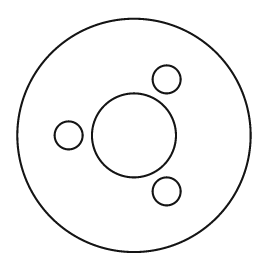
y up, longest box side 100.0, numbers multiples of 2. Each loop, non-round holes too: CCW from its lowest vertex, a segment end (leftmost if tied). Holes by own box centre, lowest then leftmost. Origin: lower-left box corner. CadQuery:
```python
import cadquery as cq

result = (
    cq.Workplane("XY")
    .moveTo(50.0, 50.0)
    .circle(50.0)
    .moveTo(64.0, 26.0)
    .circle(6.0)
    .moveTo(22.0, 50.0)
    .circle(6.0)
    .moveTo(50.0, 50.0)
    .circle(18.0)
    .moveTo(64.0, 74.0)
    .circle(6.0)
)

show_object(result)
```